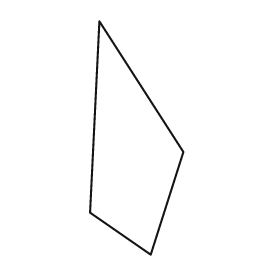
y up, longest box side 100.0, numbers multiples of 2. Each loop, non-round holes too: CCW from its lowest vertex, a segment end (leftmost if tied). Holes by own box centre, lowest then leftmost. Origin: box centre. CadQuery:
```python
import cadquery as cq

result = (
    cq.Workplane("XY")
    .moveTo(6.0, -50.0)
    .lineTo(20.0, -6.0)
    .lineTo(-16.0, 50.0)
    .lineTo(-20.0, -32.0)
    .close()
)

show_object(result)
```